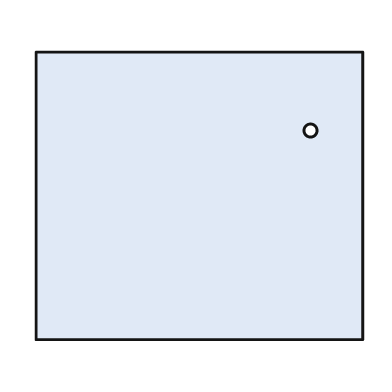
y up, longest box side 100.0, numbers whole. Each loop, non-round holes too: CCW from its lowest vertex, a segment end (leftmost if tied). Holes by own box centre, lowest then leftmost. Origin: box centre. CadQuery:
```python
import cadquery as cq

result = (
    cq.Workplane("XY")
    .moveTo(-50.0, -44.0)
    .lineTo(50.0, -44.0)
    .lineTo(50.0, 44.0)
    .lineTo(-50.0, 44.0)
    .close()
    .moveTo(34.0, 20.0)
    .circle(2.0)
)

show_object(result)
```